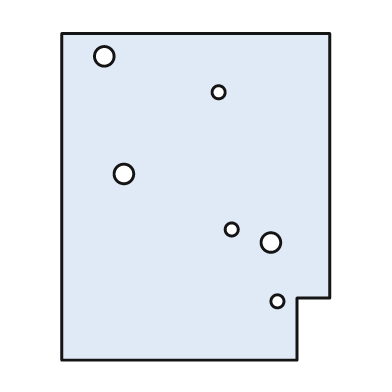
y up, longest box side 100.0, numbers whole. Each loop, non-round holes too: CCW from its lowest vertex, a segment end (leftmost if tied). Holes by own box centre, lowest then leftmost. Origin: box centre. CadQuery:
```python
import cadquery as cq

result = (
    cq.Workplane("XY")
    .moveTo(-41.0, -50.0)
    .lineTo(31.0, -50.0)
    .lineTo(31.0, -31.0)
    .lineTo(41.0, -31.0)
    .lineTo(41.0, 50.0)
    .lineTo(-41.0, 50.0)
    .close()
    .moveTo(25.0, -32.0)
    .circle(2.0)
    .moveTo(23.0, -14.0)
    .circle(3.0)
    .moveTo(11.0, -10.0)
    .circle(2.0)
    .moveTo(-22.0, 7.0)
    .circle(3.0)
    .moveTo(7.0, 32.0)
    .circle(2.0)
    .moveTo(-28.0, 43.0)
    .circle(3.0)
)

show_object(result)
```